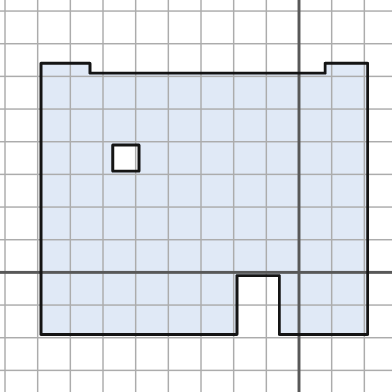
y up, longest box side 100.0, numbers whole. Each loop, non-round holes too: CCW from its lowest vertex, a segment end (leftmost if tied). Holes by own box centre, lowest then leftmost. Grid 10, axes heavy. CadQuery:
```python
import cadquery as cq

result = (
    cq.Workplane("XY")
    .moveTo(-79.0, -19.0)
    .lineTo(-19.0, -19.0)
    .lineTo(-19.0, -1.0)
    .lineTo(-6.0, -1.0)
    .lineTo(-6.0, -19.0)
    .lineTo(21.0, -19.0)
    .lineTo(21.0, 64.0)
    .lineTo(8.0, 64.0)
    .lineTo(8.0, 61.0)
    .lineTo(-64.0, 61.0)
    .lineTo(-64.0, 64.0)
    .lineTo(-79.0, 64.0)
    .close()
    .moveTo(-57.0, 31.0)
    .lineTo(-49.0, 31.0)
    .lineTo(-49.0, 39.0)
    .lineTo(-57.0, 39.0)
    .close()
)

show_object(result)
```